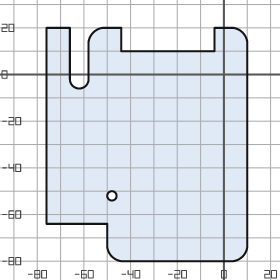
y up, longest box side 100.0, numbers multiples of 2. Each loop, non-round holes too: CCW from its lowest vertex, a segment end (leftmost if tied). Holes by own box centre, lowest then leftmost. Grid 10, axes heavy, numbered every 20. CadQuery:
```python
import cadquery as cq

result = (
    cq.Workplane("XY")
    .moveTo(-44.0, -80.0)
    .lineTo(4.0, -80.0)
    .threePointArc((8.0, -78.0), (10.0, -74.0))
    .lineTo(10.0, 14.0)
    .threePointArc((8.0, 18.0), (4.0, 20.0))
    .lineTo(-4.0, 20.0)
    .lineTo(-4.0, 10.0)
    .lineTo(-44.0, 10.0)
    .lineTo(-44.0, 20.0)
    .lineTo(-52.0, 20.0)
    .threePointArc((-56.0, 18.0), (-58.0, 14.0))
    .lineTo(-58.0, -2.0)
    .threePointArc((-62.0, -6.0), (-66.0, -2.0))
    .lineTo(-66.0, 20.0)
    .lineTo(-76.0, 20.0)
    .lineTo(-76.0, -64.0)
    .lineTo(-50.0, -64.0)
    .lineTo(-50.0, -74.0)
    .threePointArc((-48.0, -78.0), (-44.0, -80.0))
    .close()
    .moveTo(-48.0, -52.0)
    .circle(2.0)
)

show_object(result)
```